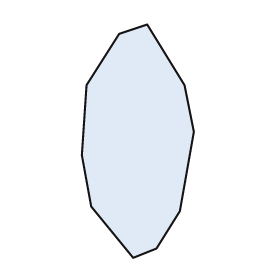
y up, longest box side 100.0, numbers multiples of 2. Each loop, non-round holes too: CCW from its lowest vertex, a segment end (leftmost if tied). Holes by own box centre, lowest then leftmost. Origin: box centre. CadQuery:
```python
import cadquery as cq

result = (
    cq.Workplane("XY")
    .moveTo(-2.0, -50.0)
    .lineTo(8.0, -46.0)
    .lineTo(18.0, -30.0)
    .lineTo(24.0, 4.0)
    .lineTo(20.0, 24.0)
    .lineTo(4.0, 50.0)
    .lineTo(-8.0, 46.0)
    .lineTo(-22.0, 24.0)
    .lineTo(-24.0, -6.0)
    .lineTo(-20.0, -28.0)
    .close()
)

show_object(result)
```